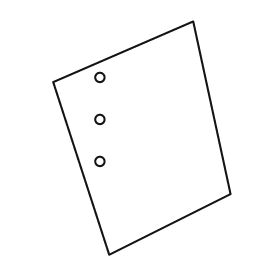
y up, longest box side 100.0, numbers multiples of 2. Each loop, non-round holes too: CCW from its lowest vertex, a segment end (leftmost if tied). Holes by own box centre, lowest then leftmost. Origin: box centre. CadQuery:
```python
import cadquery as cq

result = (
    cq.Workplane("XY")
    .moveTo(-14.0, -50.0)
    .lineTo(38.0, -24.0)
    .lineTo(22.0, 50.0)
    .lineTo(-38.0, 24.0)
    .close()
    .moveTo(-18.0, -10.0)
    .circle(2.0)
    .moveTo(-18.0, 8.0)
    .circle(2.0)
    .moveTo(-18.0, 26.0)
    .circle(2.0)
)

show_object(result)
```